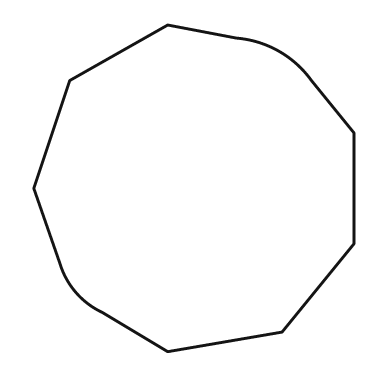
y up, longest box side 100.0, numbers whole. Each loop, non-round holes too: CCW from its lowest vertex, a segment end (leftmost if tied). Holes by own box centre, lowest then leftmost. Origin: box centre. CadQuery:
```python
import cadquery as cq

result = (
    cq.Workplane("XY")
    .moveTo(-8.0, -50.0)
    .lineTo(27.0, -44.0)
    .lineTo(49.0, -17.0)
    .lineTo(49.0, 17.0)
    .lineTo(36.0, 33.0)
    .threePointArc((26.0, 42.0), (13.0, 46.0))
    .lineTo(-8.0, 50.0)
    .lineTo(-38.0, 33.0)
    .lineTo(-49.0, 0.0)
    .lineTo(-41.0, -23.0)
    .threePointArc((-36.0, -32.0), (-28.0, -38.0))
    .close()
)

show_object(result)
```